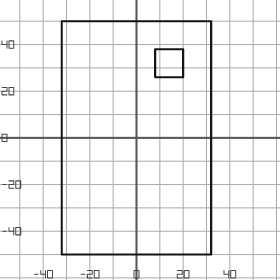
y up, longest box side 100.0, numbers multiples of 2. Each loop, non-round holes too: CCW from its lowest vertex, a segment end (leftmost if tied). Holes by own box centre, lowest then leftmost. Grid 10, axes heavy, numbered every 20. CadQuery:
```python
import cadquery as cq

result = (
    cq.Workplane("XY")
    .moveTo(-32.0, -50.0)
    .lineTo(32.0, -50.0)
    .lineTo(32.0, 50.0)
    .lineTo(-32.0, 50.0)
    .close()
    .moveTo(8.0, 26.0)
    .lineTo(20.0, 26.0)
    .lineTo(20.0, 38.0)
    .lineTo(8.0, 38.0)
    .close()
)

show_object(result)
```